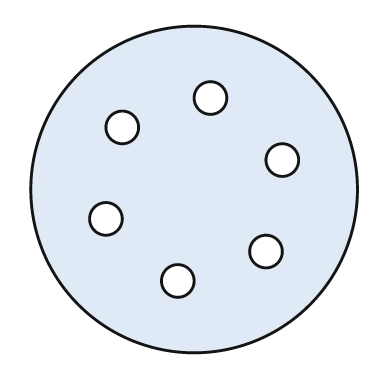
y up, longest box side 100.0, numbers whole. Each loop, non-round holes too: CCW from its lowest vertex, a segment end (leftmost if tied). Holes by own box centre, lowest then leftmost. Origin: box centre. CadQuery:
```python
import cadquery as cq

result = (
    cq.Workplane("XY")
    .moveTo(0.0, 0.0)
    .circle(50.0)
    .moveTo(-5.0, -28.0)
    .circle(5.0)
    .moveTo(22.0, -19.0)
    .circle(5.0)
    .moveTo(-27.0, -9.0)
    .circle(5.0)
    .moveTo(27.0, 9.0)
    .circle(5.0)
    .moveTo(-22.0, 19.0)
    .circle(5.0)
    .moveTo(5.0, 28.0)
    .circle(5.0)
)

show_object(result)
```